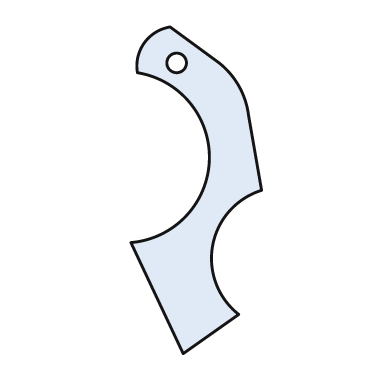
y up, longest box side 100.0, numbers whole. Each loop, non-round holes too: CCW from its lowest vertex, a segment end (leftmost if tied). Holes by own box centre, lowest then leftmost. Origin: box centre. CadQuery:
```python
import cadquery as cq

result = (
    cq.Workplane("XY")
    .moveTo(-4.0, -50.0)
    .lineTo(13.0, -38.0)
    .threePointArc((5.0, -17.0), (20.0, 0.0))
    .lineTo(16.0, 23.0)
    .threePointArc((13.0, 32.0), (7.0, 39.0))
    .lineTo(-8.0, 50.0)
    .threePointArc((-16.0, 45.0), (-18.0, 36.0))
    .threePointArc((4.0, 9.0), (-20.0, -16.0))
    .close()
    .moveTo(-6.0, 39.0)
    .circle(3.0)
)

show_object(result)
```